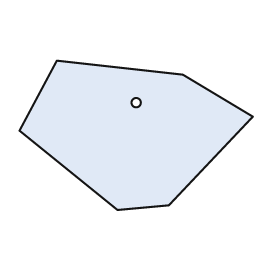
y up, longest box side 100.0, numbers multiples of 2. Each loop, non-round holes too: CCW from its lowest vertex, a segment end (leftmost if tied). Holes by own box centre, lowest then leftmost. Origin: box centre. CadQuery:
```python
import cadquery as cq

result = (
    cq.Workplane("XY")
    .moveTo(-8.0, -32.0)
    .lineTo(14.0, -30.0)
    .lineTo(50.0, 8.0)
    .lineTo(20.0, 26.0)
    .lineTo(-34.0, 32.0)
    .lineTo(-50.0, 2.0)
    .close()
    .moveTo(0.0, 14.0)
    .circle(2.0)
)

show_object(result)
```